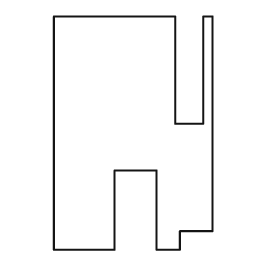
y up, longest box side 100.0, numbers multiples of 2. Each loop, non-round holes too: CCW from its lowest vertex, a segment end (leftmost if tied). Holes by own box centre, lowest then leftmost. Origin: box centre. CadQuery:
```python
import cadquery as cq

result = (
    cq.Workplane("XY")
    .moveTo(-34.0, -50.0)
    .lineTo(-8.0, -50.0)
    .lineTo(-8.0, -16.0)
    .lineTo(10.0, -16.0)
    .lineTo(10.0, -50.0)
    .lineTo(20.0, -50.0)
    .lineTo(20.0, -42.0)
    .lineTo(34.0, -42.0)
    .lineTo(34.0, 50.0)
    .lineTo(30.0, 50.0)
    .lineTo(30.0, 4.0)
    .lineTo(18.0, 4.0)
    .lineTo(18.0, 50.0)
    .lineTo(-34.0, 50.0)
    .close()
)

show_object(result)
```